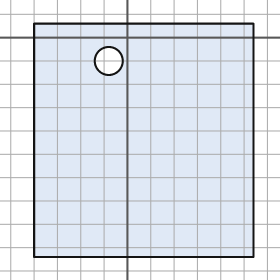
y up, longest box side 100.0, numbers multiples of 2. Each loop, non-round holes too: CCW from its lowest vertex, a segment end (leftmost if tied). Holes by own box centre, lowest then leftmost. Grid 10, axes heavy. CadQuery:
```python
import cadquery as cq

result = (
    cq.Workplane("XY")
    .moveTo(-40.0, -94.0)
    .lineTo(54.0, -94.0)
    .lineTo(54.0, 6.0)
    .lineTo(-40.0, 6.0)
    .close()
    .moveTo(-8.0, -10.0)
    .circle(6.0)
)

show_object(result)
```